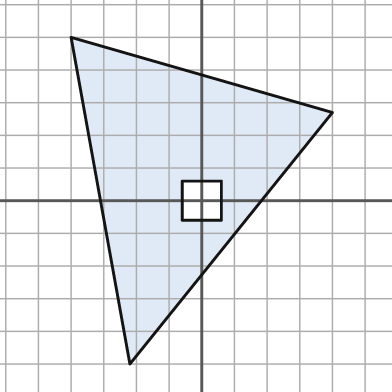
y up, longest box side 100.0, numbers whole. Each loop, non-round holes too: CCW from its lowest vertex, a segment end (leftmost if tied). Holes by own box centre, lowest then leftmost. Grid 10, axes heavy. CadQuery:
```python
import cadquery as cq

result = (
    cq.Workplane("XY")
    .moveTo(-22.0, -50.0)
    .lineTo(40.0, 27.0)
    .lineTo(-40.0, 50.0)
    .close()
    .moveTo(-6.0, -6.0)
    .lineTo(6.0, -6.0)
    .lineTo(6.0, 6.0)
    .lineTo(-6.0, 6.0)
    .close()
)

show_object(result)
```